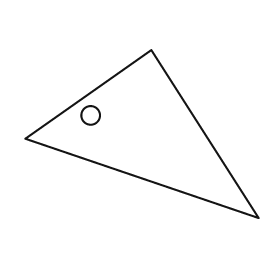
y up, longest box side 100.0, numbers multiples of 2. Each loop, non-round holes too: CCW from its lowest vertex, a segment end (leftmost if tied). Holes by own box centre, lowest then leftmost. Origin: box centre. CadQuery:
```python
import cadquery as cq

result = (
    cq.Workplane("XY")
    .moveTo(50.0, -36.0)
    .lineTo(4.0, 36.0)
    .lineTo(-50.0, -2.0)
    .close()
    .moveTo(-22.0, 8.0)
    .circle(4.0)
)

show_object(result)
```